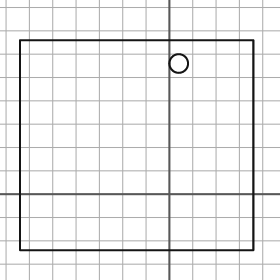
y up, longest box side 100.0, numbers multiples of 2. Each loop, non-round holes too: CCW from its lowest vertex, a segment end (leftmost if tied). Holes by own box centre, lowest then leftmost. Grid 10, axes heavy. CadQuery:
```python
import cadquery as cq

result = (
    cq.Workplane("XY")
    .moveTo(-64.0, -24.0)
    .lineTo(36.0, -24.0)
    .lineTo(36.0, 66.0)
    .lineTo(-64.0, 66.0)
    .close()
    .moveTo(4.0, 56.0)
    .circle(4.0)
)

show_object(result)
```